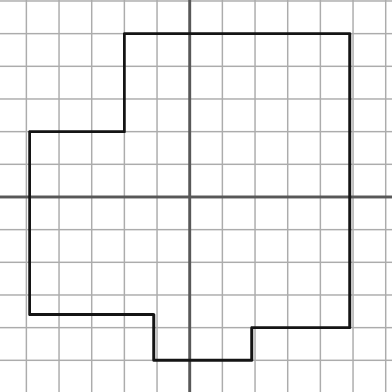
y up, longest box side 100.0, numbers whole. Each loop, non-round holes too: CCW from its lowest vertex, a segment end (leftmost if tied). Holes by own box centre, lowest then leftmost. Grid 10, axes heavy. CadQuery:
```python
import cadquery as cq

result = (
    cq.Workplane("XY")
    .moveTo(-11.0, -50.0)
    .lineTo(19.0, -50.0)
    .lineTo(19.0, -40.0)
    .lineTo(49.0, -40.0)
    .lineTo(49.0, 50.0)
    .lineTo(-20.0, 50.0)
    .lineTo(-20.0, 20.0)
    .lineTo(-49.0, 20.0)
    .lineTo(-49.0, -36.0)
    .lineTo(-11.0, -36.0)
    .close()
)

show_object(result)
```